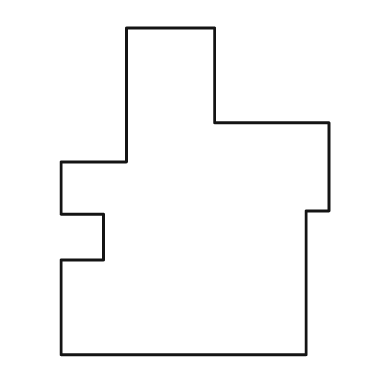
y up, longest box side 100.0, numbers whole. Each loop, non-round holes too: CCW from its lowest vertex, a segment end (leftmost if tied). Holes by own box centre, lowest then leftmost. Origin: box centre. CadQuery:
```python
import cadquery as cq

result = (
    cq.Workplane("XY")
    .moveTo(-41.0, -50.0)
    .lineTo(34.0, -50.0)
    .lineTo(34.0, -6.0)
    .lineTo(41.0, -6.0)
    .lineTo(41.0, 21.0)
    .lineTo(6.0, 21.0)
    .lineTo(6.0, 50.0)
    .lineTo(-21.0, 50.0)
    .lineTo(-21.0, 9.0)
    .lineTo(-41.0, 9.0)
    .lineTo(-41.0, -7.0)
    .lineTo(-28.0, -7.0)
    .lineTo(-28.0, -21.0)
    .lineTo(-41.0, -21.0)
    .close()
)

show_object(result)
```